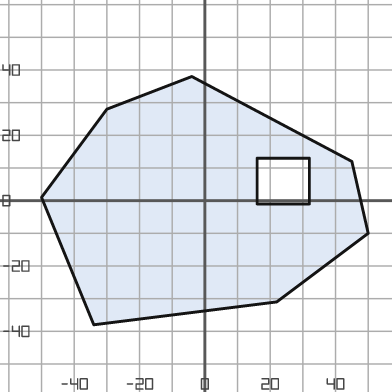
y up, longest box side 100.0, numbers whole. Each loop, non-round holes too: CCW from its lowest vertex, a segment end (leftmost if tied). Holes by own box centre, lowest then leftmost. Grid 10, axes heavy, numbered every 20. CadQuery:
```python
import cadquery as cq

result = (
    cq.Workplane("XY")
    .moveTo(-34.0, -38.0)
    .lineTo(22.0, -31.0)
    .lineTo(50.0, -10.0)
    .lineTo(45.0, 12.0)
    .lineTo(-4.0, 38.0)
    .lineTo(-30.0, 28.0)
    .lineTo(-50.0, 1.0)
    .close()
    .moveTo(16.0, -1.0)
    .lineTo(32.0, -1.0)
    .lineTo(32.0, 13.0)
    .lineTo(16.0, 13.0)
    .close()
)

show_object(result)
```